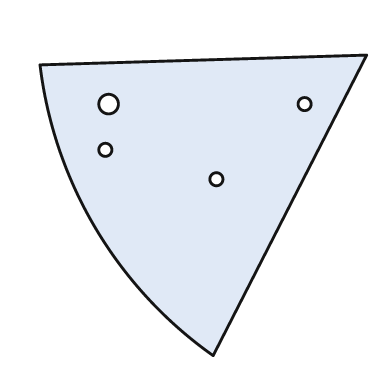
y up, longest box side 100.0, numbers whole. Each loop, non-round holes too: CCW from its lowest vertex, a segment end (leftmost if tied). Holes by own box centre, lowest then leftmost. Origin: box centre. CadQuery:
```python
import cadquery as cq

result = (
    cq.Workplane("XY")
    .moveTo(3.0, -46.0)
    .lineTo(50.0, 46.0)
    .lineTo(-50.0, 43.0)
    .threePointArc((-33.0, -7.0), (3.0, -46.0))
    .close()
    .moveTo(4.0, 8.0)
    .circle(2.0)
    .moveTo(-30.0, 17.0)
    .circle(2.0)
    .moveTo(-29.0, 31.0)
    .circle(3.0)
    .moveTo(31.0, 31.0)
    .circle(2.0)
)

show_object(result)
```